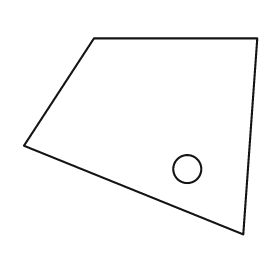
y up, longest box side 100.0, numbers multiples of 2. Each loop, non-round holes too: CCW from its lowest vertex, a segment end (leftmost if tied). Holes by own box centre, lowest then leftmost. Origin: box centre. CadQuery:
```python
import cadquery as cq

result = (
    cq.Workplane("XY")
    .moveTo(44.0, -42.0)
    .lineTo(50.0, 42.0)
    .lineTo(-20.0, 42.0)
    .lineTo(-50.0, -4.0)
    .close()
    .moveTo(20.0, -14.0)
    .circle(6.0)
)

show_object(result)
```